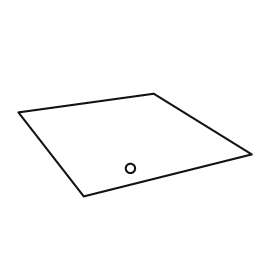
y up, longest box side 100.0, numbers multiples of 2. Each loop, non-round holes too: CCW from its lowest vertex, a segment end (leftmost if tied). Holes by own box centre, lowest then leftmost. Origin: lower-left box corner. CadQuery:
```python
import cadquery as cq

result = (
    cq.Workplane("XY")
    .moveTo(28.0, 0.0)
    .lineTo(100.0, 18.0)
    .lineTo(58.0, 44.0)
    .lineTo(0.0, 36.0)
    .close()
    .moveTo(48.0, 12.0)
    .circle(2.0)
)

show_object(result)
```